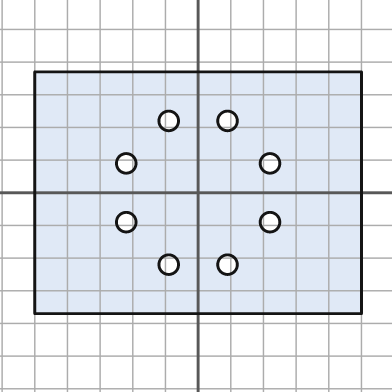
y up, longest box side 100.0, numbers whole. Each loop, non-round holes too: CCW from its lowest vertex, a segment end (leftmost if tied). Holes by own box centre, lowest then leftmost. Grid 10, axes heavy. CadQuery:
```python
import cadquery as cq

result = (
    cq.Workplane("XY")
    .moveTo(-50.0, -37.0)
    .lineTo(50.0, -37.0)
    .lineTo(50.0, 37.0)
    .lineTo(-50.0, 37.0)
    .close()
    .moveTo(-9.0, -22.0)
    .circle(3.0)
    .moveTo(9.0, -22.0)
    .circle(3.0)
    .moveTo(-22.0, -9.0)
    .circle(3.0)
    .moveTo(22.0, -9.0)
    .circle(3.0)
    .moveTo(-22.0, 9.0)
    .circle(3.0)
    .moveTo(22.0, 9.0)
    .circle(3.0)
    .moveTo(-9.0, 22.0)
    .circle(3.0)
    .moveTo(9.0, 22.0)
    .circle(3.0)
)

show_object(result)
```